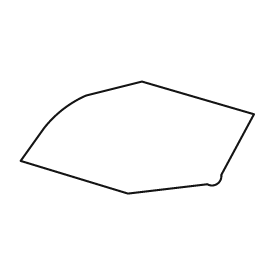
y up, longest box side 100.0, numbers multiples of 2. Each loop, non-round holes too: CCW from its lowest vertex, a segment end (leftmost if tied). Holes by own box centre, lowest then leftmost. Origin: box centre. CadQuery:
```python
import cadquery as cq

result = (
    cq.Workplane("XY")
    .moveTo(-4.0, -24.0)
    .lineTo(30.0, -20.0)
    .threePointArc((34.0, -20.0), (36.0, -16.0))
    .lineTo(50.0, 10.0)
    .lineTo(2.0, 24.0)
    .lineTo(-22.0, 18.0)
    .threePointArc((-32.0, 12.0), (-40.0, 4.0))
    .lineTo(-50.0, -10.0)
    .close()
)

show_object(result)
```